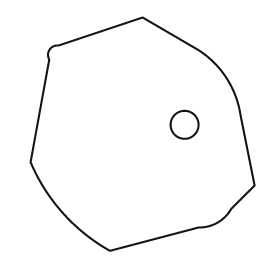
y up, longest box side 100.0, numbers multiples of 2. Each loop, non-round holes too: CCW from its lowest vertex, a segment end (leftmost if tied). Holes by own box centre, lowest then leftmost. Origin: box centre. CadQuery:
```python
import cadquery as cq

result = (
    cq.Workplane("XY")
    .moveTo(-14.0, -50.0)
    .lineTo(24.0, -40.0)
    .threePointArc((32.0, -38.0), (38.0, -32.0))
    .lineTo(48.0, -22.0)
    .lineTo(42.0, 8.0)
    .threePointArc((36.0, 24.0), (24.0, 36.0))
    .lineTo(0.0, 50.0)
    .lineTo(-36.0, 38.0)
    .threePointArc((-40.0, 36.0), (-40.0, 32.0))
    .lineTo(-48.0, -12.0)
    .threePointArc((-34.0, -34.0), (-14.0, -50.0))
    .close()
    .moveTo(18.0, 4.0)
    .circle(6.0)
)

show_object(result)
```